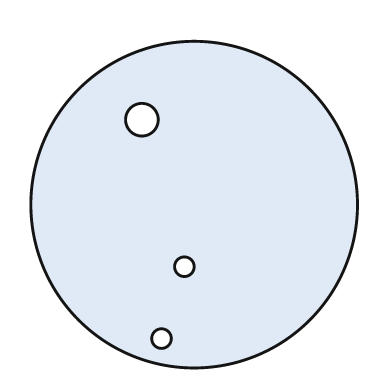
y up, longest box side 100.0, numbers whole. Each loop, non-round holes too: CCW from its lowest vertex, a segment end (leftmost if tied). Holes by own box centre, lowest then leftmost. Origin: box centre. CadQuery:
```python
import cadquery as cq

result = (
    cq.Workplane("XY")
    .moveTo(0.0, 0.0)
    .circle(50.0)
    .moveTo(-10.0, -41.0)
    .circle(3.0)
    .moveTo(-3.0, -19.0)
    .circle(3.0)
    .moveTo(-16.0, 26.0)
    .circle(5.0)
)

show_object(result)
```